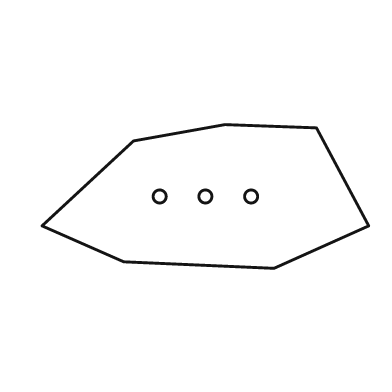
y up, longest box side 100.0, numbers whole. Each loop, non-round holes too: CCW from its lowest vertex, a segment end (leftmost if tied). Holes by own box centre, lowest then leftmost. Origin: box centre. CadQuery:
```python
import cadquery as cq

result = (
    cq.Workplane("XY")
    .moveTo(21.0, -22.0)
    .lineTo(50.0, -9.0)
    .lineTo(34.0, 21.0)
    .lineTo(6.0, 22.0)
    .lineTo(-22.0, 17.0)
    .lineTo(-50.0, -9.0)
    .lineTo(-25.0, -20.0)
    .close()
    .moveTo(-14.0, 0.0)
    .circle(2.0)
    .moveTo(0.0, 0.0)
    .circle(2.0)
    .moveTo(14.0, 0.0)
    .circle(2.0)
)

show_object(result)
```